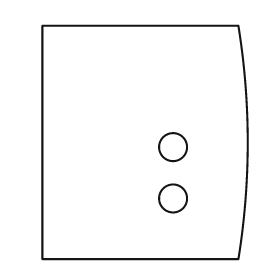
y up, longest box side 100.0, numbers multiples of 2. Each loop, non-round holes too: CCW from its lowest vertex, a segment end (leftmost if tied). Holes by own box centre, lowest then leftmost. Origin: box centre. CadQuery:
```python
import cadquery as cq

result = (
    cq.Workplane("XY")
    .moveTo(-44.0, -50.0)
    .lineTo(40.0, -50.0)
    .threePointArc((44.0, 0.0), (40.0, 50.0))
    .lineTo(-44.0, 50.0)
    .close()
    .moveTo(12.0, -24.0)
    .circle(6.0)
    .moveTo(12.0, -2.0)
    .circle(6.0)
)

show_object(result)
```